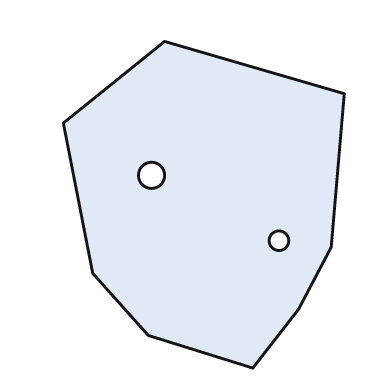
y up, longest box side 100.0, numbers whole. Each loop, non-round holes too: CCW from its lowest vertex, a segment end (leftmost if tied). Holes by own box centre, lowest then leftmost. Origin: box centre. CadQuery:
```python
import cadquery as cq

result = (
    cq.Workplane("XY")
    .moveTo(15.0, -50.0)
    .lineTo(29.0, -32.0)
    .lineTo(39.0, -13.0)
    .lineTo(43.0, 34.0)
    .lineTo(-12.0, 50.0)
    .lineTo(-43.0, 25.0)
    .lineTo(-34.0, -21.0)
    .lineTo(-17.0, -40.0)
    .close()
    .moveTo(23.0, -11.0)
    .circle(3.0)
    .moveTo(-16.0, 9.0)
    .circle(4.0)
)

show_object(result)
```